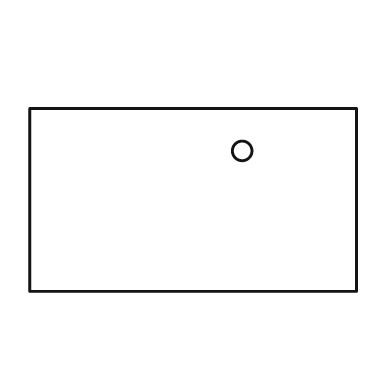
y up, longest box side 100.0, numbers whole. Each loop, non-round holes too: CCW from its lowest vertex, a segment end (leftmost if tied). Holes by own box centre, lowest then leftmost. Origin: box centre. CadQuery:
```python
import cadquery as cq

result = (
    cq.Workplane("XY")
    .moveTo(-50.0, -28.0)
    .lineTo(50.0, -28.0)
    .lineTo(50.0, 28.0)
    .lineTo(-50.0, 28.0)
    .close()
    .moveTo(15.0, 15.0)
    .circle(3.0)
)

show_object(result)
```